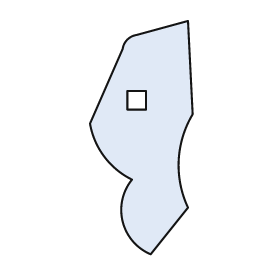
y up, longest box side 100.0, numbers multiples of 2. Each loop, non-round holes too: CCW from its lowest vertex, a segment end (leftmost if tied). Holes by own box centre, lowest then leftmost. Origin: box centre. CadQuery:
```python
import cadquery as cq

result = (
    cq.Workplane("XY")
    .moveTo(4.0, -50.0)
    .lineTo(20.0, -30.0)
    .threePointArc((16.0, -10.0), (22.0, 10.0))
    .lineTo(20.0, 50.0)
    .lineTo(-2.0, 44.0)
    .threePointArc((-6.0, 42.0), (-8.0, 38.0))
    .lineTo(-22.0, 6.0)
    .threePointArc((-16.0, -8.0), (-4.0, -18.0))
    .threePointArc((-8.0, -36.0), (4.0, -50.0))
    .close()
    .moveTo(-6.0, 12.0)
    .lineTo(2.0, 12.0)
    .lineTo(2.0, 20.0)
    .lineTo(-6.0, 20.0)
    .close()
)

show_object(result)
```